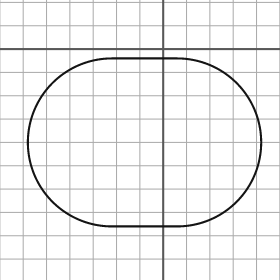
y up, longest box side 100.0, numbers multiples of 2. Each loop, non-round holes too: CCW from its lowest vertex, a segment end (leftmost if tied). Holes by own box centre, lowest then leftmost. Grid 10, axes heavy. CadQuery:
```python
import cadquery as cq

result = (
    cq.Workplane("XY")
    .moveTo(-22.0, -76.0)
    .lineTo(6.0, -76.0)
    .threePointArc((42.0, -40.0), (6.0, -4.0))
    .lineTo(-22.0, -4.0)
    .threePointArc((-58.0, -40.0), (-22.0, -76.0))
    .close()
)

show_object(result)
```